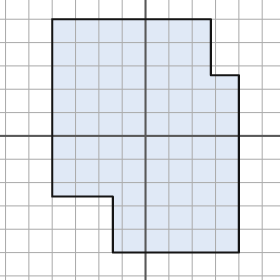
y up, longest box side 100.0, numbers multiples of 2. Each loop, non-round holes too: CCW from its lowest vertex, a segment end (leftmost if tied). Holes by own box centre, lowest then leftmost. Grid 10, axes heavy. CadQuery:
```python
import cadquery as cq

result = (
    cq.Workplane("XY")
    .moveTo(-14.0, -50.0)
    .lineTo(40.0, -50.0)
    .lineTo(40.0, 26.0)
    .lineTo(28.0, 26.0)
    .lineTo(28.0, 50.0)
    .lineTo(-40.0, 50.0)
    .lineTo(-40.0, -26.0)
    .lineTo(-14.0, -26.0)
    .close()
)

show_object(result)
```